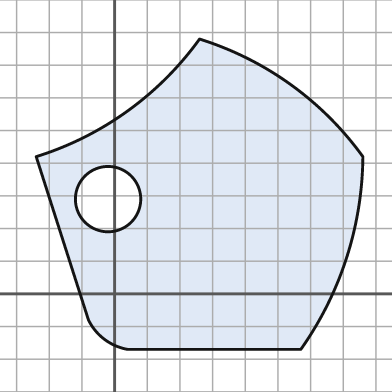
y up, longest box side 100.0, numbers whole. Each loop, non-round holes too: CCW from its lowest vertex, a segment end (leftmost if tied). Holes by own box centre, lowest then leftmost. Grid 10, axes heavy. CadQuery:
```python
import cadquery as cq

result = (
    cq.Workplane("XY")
    .moveTo(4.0, -17.0)
    .lineTo(57.0, -17.0)
    .threePointArc((71.0, 11.0), (76.0, 42.0))
    .threePointArc((54.0, 64.0), (26.0, 78.0))
    .threePointArc((4.0, 56.0), (-24.0, 42.0))
    .lineTo(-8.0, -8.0)
    .threePointArc((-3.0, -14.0), (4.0, -17.0))
    .close()
    .moveTo(-2.0, 29.0)
    .circle(10.0)
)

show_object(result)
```